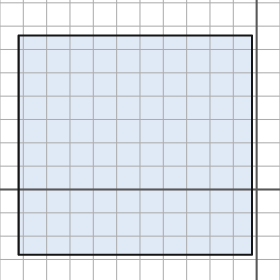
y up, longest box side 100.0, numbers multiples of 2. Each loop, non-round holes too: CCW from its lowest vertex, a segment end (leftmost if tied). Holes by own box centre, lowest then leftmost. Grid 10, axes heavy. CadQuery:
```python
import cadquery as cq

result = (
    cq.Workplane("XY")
    .moveTo(-102.0, -28.0)
    .lineTo(-2.0, -28.0)
    .lineTo(-2.0, 66.0)
    .lineTo(-102.0, 66.0)
    .close()
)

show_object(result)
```